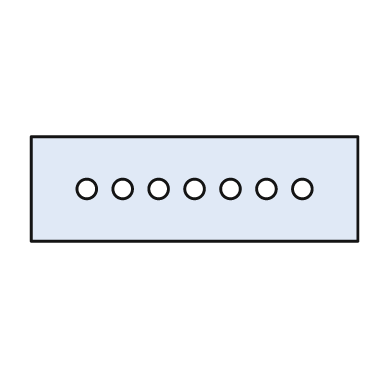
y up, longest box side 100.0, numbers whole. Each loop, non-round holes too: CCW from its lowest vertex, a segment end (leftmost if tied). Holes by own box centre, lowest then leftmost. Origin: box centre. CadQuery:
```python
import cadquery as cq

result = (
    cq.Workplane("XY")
    .moveTo(-50.0, -16.0)
    .lineTo(50.0, -16.0)
    .lineTo(50.0, 16.0)
    .lineTo(-50.0, 16.0)
    .close()
    .moveTo(-33.0, 0.0)
    .circle(3.0)
    .moveTo(-22.0, 0.0)
    .circle(3.0)
    .moveTo(-11.0, 0.0)
    .circle(3.0)
    .moveTo(0.0, 0.0)
    .circle(3.0)
    .moveTo(11.0, 0.0)
    .circle(3.0)
    .moveTo(22.0, 0.0)
    .circle(3.0)
    .moveTo(33.0, 0.0)
    .circle(3.0)
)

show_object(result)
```